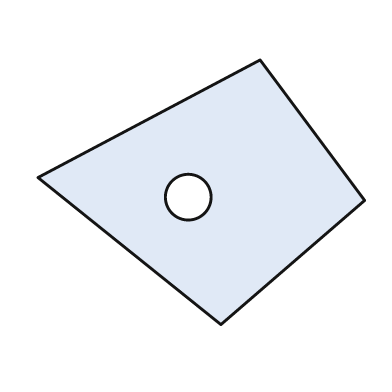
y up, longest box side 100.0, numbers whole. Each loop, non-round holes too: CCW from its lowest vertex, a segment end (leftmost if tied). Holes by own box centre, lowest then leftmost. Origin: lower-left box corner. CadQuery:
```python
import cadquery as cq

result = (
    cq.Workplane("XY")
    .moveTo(56.0, 0.0)
    .lineTo(100.0, 38.0)
    .lineTo(68.0, 81.0)
    .lineTo(0.0, 45.0)
    .close()
    .moveTo(46.0, 39.0)
    .circle(7.0)
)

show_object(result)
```